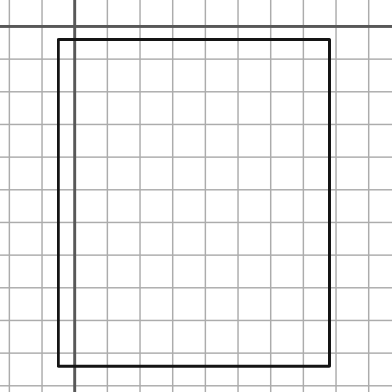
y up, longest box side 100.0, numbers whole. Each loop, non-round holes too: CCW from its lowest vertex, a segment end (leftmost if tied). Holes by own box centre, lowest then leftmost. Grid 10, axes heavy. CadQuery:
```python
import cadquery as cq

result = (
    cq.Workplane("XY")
    .moveTo(-5.0, -104.0)
    .lineTo(78.0, -104.0)
    .lineTo(78.0, -4.0)
    .lineTo(-5.0, -4.0)
    .close()
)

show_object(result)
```